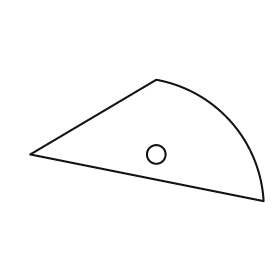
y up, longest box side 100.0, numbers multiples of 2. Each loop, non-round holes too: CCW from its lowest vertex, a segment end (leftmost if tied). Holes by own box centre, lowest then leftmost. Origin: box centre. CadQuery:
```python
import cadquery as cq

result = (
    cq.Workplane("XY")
    .moveTo(50.0, -26.0)
    .threePointArc((36.0, 8.0), (4.0, 26.0))
    .lineTo(-50.0, -6.0)
    .close()
    .moveTo(4.0, -6.0)
    .circle(4.0)
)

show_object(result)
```